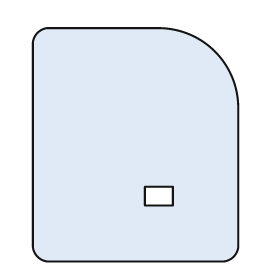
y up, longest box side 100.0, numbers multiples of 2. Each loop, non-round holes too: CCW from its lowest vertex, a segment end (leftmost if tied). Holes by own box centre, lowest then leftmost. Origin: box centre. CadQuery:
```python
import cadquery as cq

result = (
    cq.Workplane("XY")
    .moveTo(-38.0, -50.0)
    .lineTo(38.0, -50.0)
    .threePointArc((42.0, -48.0), (44.0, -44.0))
    .lineTo(44.0, 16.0)
    .threePointArc((34.0, 40.0), (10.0, 50.0))
    .lineTo(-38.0, 50.0)
    .threePointArc((-42.0, 48.0), (-44.0, 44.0))
    .lineTo(-44.0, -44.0)
    .threePointArc((-42.0, -48.0), (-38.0, -50.0))
    .close()
    .moveTo(4.0, -26.0)
    .lineTo(16.0, -26.0)
    .lineTo(16.0, -18.0)
    .lineTo(4.0, -18.0)
    .close()
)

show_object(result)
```